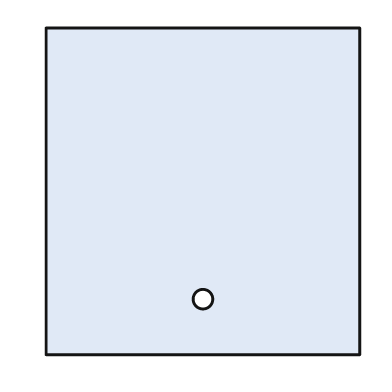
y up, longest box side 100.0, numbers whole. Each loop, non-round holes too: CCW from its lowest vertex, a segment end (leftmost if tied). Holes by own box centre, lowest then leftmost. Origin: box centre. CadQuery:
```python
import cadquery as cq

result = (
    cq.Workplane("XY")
    .moveTo(-48.0, -50.0)
    .lineTo(48.0, -50.0)
    .lineTo(48.0, 50.0)
    .lineTo(-48.0, 50.0)
    .close()
    .moveTo(0.0, -33.0)
    .circle(3.0)
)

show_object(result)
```